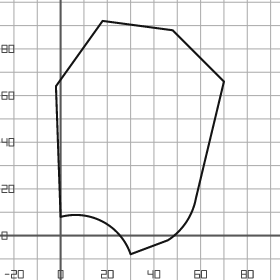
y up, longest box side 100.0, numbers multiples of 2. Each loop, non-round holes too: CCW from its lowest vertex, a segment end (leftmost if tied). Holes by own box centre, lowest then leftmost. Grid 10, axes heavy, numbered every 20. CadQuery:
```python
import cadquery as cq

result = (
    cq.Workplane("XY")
    .moveTo(30.0, -8.0)
    .lineTo(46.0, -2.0)
    .threePointArc((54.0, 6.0), (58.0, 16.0))
    .lineTo(70.0, 66.0)
    .lineTo(48.0, 88.0)
    .lineTo(18.0, 92.0)
    .lineTo(-2.0, 64.0)
    .lineTo(0.0, 8.0)
    .threePointArc((18.0, 6.0), (30.0, -8.0))
    .close()
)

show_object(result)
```